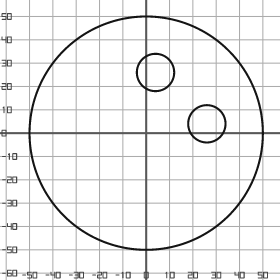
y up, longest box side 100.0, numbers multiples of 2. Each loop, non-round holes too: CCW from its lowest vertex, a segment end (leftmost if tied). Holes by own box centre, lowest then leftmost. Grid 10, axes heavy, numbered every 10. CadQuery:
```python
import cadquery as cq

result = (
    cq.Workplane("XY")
    .moveTo(0.0, 0.0)
    .circle(50.0)
    .moveTo(26.0, 4.0)
    .circle(8.0)
    .moveTo(4.0, 26.0)
    .circle(8.0)
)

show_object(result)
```